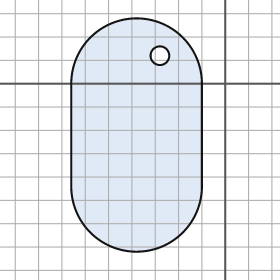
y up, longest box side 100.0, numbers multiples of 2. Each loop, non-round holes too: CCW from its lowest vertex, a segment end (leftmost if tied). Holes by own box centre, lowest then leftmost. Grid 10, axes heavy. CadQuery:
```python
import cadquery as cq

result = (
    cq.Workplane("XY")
    .moveTo(-66.0, -44.0)
    .threePointArc((-38.0, -72.0), (-10.0, -44.0))
    .lineTo(-10.0, 0.0)
    .threePointArc((-38.0, 28.0), (-66.0, 0.0))
    .close()
    .moveTo(-28.0, 12.0)
    .circle(4.0)
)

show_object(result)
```